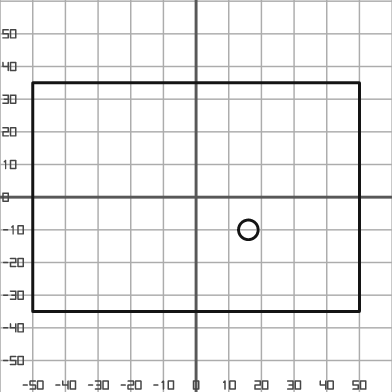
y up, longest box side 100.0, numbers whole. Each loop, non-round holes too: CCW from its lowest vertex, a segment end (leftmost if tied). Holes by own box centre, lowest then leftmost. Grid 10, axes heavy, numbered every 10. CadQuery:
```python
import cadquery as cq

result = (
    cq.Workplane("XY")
    .moveTo(-50.0, -35.0)
    .lineTo(50.0, -35.0)
    .lineTo(50.0, 35.0)
    .lineTo(-50.0, 35.0)
    .close()
    .moveTo(16.0, -10.0)
    .circle(3.0)
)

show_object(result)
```